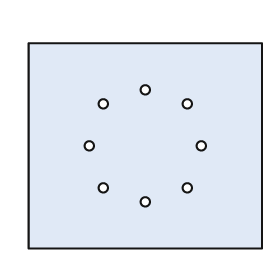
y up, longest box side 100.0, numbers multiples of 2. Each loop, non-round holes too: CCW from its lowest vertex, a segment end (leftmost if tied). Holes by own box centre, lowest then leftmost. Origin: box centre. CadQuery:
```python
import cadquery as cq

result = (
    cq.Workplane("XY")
    .moveTo(-50.0, -44.0)
    .lineTo(50.0, -44.0)
    .lineTo(50.0, 44.0)
    .lineTo(-50.0, 44.0)
    .close()
    .moveTo(0.0, -24.0)
    .circle(2.0)
    .moveTo(-18.0, -18.0)
    .circle(2.0)
    .moveTo(18.0, -18.0)
    .circle(2.0)
    .moveTo(-24.0, 0.0)
    .circle(2.0)
    .moveTo(24.0, 0.0)
    .circle(2.0)
    .moveTo(-18.0, 18.0)
    .circle(2.0)
    .moveTo(18.0, 18.0)
    .circle(2.0)
    .moveTo(0.0, 24.0)
    .circle(2.0)
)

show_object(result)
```